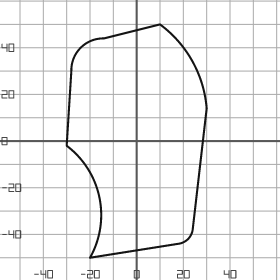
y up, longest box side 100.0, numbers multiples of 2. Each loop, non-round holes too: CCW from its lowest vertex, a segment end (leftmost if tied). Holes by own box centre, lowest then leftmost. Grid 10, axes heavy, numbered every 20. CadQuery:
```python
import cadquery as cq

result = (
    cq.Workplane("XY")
    .moveTo(-20.0, -50.0)
    .lineTo(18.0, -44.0)
    .threePointArc((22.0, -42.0), (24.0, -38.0))
    .lineTo(30.0, 14.0)
    .threePointArc((24.0, 34.0), (10.0, 50.0))
    .lineTo(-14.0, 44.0)
    .threePointArc((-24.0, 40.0), (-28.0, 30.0))
    .lineTo(-30.0, -2.0)
    .threePointArc((-16.0, -24.0), (-20.0, -50.0))
    .close()
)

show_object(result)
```